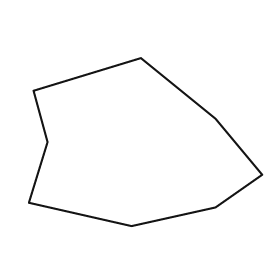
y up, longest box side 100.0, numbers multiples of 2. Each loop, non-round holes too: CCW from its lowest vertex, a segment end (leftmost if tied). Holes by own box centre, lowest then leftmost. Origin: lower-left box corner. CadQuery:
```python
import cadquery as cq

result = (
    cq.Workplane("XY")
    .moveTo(44.0, 0.0)
    .lineTo(80.0, 8.0)
    .lineTo(100.0, 22.0)
    .lineTo(80.0, 46.0)
    .lineTo(48.0, 72.0)
    .lineTo(2.0, 58.0)
    .lineTo(8.0, 36.0)
    .lineTo(0.0, 10.0)
    .close()
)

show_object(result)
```